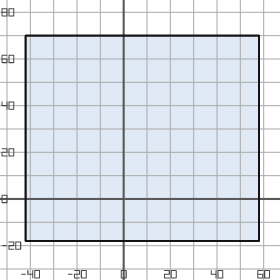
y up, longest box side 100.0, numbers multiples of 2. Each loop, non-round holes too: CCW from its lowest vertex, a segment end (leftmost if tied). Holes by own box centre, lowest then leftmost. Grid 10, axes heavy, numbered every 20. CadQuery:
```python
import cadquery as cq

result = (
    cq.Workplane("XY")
    .moveTo(-42.0, -18.0)
    .lineTo(58.0, -18.0)
    .lineTo(58.0, 70.0)
    .lineTo(-42.0, 70.0)
    .close()
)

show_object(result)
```